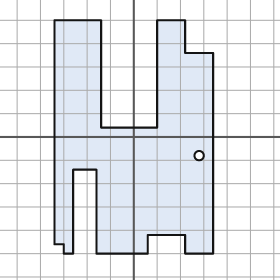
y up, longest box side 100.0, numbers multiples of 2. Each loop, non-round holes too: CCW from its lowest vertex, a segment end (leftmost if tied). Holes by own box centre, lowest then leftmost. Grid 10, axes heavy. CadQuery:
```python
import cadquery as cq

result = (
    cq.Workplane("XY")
    .moveTo(-30.0, -50.0)
    .lineTo(-26.0, -50.0)
    .lineTo(-26.0, -14.0)
    .lineTo(-16.0, -14.0)
    .lineTo(-16.0, -50.0)
    .lineTo(6.0, -50.0)
    .lineTo(6.0, -42.0)
    .lineTo(22.0, -42.0)
    .lineTo(22.0, -50.0)
    .lineTo(34.0, -50.0)
    .lineTo(34.0, 36.0)
    .lineTo(22.0, 36.0)
    .lineTo(22.0, 50.0)
    .lineTo(10.0, 50.0)
    .lineTo(10.0, 4.0)
    .lineTo(-14.0, 4.0)
    .lineTo(-14.0, 50.0)
    .lineTo(-34.0, 50.0)
    .lineTo(-34.0, -46.0)
    .lineTo(-30.0, -46.0)
    .close()
    .moveTo(28.0, -8.0)
    .circle(2.0)
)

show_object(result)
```